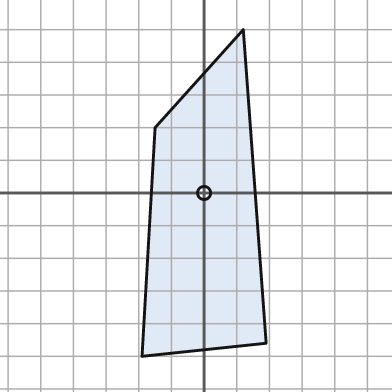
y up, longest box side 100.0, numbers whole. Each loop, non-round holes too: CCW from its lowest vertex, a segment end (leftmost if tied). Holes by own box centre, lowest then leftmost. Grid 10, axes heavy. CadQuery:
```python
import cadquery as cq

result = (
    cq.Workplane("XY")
    .moveTo(-19.0, -50.0)
    .lineTo(19.0, -46.0)
    .lineTo(12.0, 50.0)
    .lineTo(-15.0, 20.0)
    .close()
    .moveTo(0.0, 0.0)
    .circle(2.0)
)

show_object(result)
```